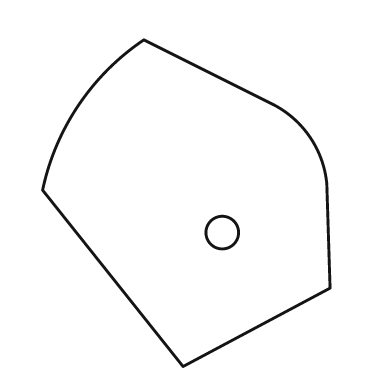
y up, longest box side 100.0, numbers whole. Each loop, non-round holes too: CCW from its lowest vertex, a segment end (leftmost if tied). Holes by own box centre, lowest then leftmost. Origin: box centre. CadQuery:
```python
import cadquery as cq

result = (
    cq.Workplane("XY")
    .moveTo(-1.0, -50.0)
    .lineTo(44.0, -26.0)
    .lineTo(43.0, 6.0)
    .threePointArc((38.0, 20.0), (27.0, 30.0))
    .lineTo(-13.0, 50.0)
    .threePointArc((-33.0, 30.0), (-44.0, 4.0))
    .close()
    .moveTo(11.0, -9.0)
    .circle(5.0)
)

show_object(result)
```